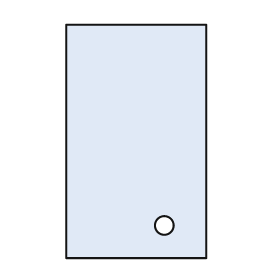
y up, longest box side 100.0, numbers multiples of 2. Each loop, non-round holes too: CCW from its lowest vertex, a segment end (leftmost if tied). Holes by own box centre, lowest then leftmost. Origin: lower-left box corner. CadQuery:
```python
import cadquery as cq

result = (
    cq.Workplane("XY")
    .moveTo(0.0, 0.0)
    .lineTo(60.0, 0.0)
    .lineTo(60.0, 100.0)
    .lineTo(0.0, 100.0)
    .close()
    .moveTo(42.0, 14.0)
    .circle(4.0)
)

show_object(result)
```